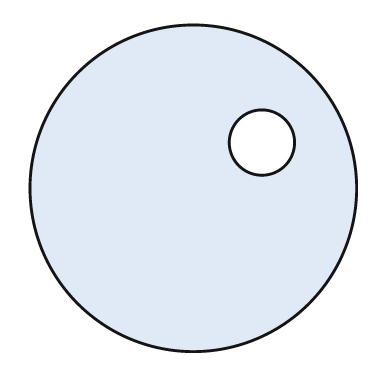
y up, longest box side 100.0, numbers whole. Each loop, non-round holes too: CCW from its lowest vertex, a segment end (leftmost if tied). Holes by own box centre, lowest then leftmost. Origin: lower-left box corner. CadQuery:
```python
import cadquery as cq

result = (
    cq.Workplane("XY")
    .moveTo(50.0, 50.0)
    .circle(50.0)
    .moveTo(71.0, 64.0)
    .circle(10.0)
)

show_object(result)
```